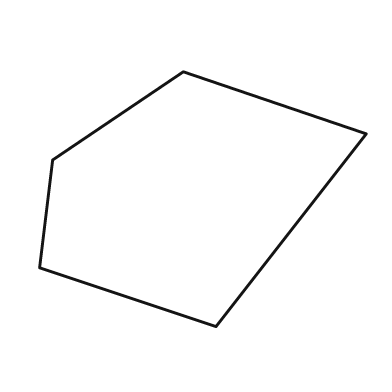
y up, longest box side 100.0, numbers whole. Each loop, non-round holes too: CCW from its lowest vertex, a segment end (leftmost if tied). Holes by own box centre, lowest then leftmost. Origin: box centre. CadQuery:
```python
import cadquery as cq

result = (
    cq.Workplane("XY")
    .moveTo(4.0, -39.0)
    .lineTo(50.0, 20.0)
    .lineTo(-6.0, 39.0)
    .lineTo(-46.0, 12.0)
    .lineTo(-50.0, -21.0)
    .close()
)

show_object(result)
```